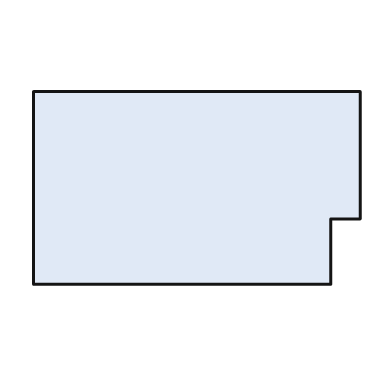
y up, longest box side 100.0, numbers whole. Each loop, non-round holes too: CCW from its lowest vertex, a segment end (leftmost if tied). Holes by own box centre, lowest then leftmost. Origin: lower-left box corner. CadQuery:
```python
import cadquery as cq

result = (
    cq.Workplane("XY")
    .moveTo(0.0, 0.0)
    .lineTo(91.0, 0.0)
    .lineTo(91.0, 20.0)
    .lineTo(100.0, 20.0)
    .lineTo(100.0, 59.0)
    .lineTo(0.0, 59.0)
    .close()
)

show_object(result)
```